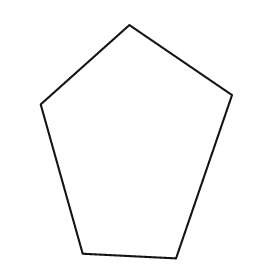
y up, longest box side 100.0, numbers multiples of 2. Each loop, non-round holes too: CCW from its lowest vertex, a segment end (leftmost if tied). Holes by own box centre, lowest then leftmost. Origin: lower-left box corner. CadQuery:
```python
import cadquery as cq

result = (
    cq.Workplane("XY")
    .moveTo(58.0, 0.0)
    .lineTo(82.0, 70.0)
    .lineTo(38.0, 100.0)
    .lineTo(0.0, 66.0)
    .lineTo(18.0, 2.0)
    .close()
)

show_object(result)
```